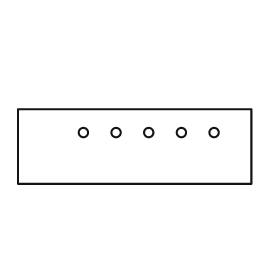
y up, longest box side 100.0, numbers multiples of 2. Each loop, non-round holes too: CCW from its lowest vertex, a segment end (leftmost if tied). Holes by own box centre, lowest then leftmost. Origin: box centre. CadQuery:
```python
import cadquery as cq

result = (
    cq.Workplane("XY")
    .moveTo(-50.0, -16.0)
    .lineTo(50.0, -16.0)
    .lineTo(50.0, 16.0)
    .lineTo(-50.0, 16.0)
    .close()
    .moveTo(-22.0, 6.0)
    .circle(2.0)
    .moveTo(-8.0, 6.0)
    .circle(2.0)
    .moveTo(6.0, 6.0)
    .circle(2.0)
    .moveTo(20.0, 6.0)
    .circle(2.0)
    .moveTo(34.0, 6.0)
    .circle(2.0)
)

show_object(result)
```